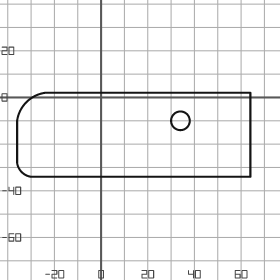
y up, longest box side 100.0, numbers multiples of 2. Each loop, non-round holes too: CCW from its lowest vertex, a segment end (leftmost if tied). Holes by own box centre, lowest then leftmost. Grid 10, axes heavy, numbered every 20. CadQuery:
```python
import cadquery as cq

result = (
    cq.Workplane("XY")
    .moveTo(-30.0, -34.0)
    .lineTo(64.0, -34.0)
    .lineTo(64.0, 2.0)
    .lineTo(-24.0, 2.0)
    .threePointArc((-32.0, -2.0), (-36.0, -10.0))
    .lineTo(-36.0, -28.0)
    .threePointArc((-34.0, -32.0), (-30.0, -34.0))
    .close()
    .moveTo(34.0, -10.0)
    .circle(4.0)
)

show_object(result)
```